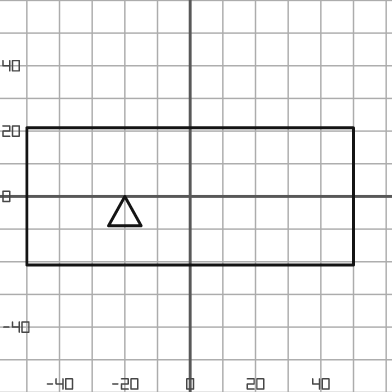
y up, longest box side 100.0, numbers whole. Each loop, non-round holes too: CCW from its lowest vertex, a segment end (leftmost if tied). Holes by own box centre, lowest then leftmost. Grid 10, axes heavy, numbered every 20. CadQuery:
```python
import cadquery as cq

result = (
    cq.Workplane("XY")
    .moveTo(-50.0, -21.0)
    .lineTo(50.0, -21.0)
    .lineTo(50.0, 21.0)
    .lineTo(-50.0, 21.0)
    .close()
    .moveTo(-25.0, -9.0)
    .lineTo(-15.0, -9.0)
    .lineTo(-20.0, 0.0)
    .close()
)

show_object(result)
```